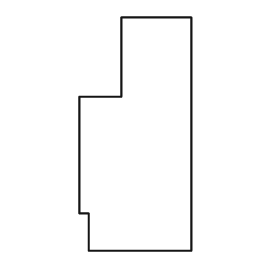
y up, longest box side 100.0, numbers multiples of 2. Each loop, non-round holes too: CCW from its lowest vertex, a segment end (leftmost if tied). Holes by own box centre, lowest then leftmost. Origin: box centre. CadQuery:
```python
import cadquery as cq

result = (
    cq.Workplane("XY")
    .moveTo(-20.0, -50.0)
    .lineTo(24.0, -50.0)
    .lineTo(24.0, 50.0)
    .lineTo(-6.0, 50.0)
    .lineTo(-6.0, 16.0)
    .lineTo(-24.0, 16.0)
    .lineTo(-24.0, -34.0)
    .lineTo(-20.0, -34.0)
    .close()
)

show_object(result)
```